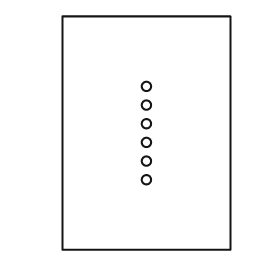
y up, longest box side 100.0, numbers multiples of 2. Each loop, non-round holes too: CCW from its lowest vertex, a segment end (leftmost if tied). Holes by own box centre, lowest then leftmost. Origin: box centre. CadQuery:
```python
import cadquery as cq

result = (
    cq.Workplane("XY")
    .moveTo(-36.0, -50.0)
    .lineTo(36.0, -50.0)
    .lineTo(36.0, 50.0)
    .lineTo(-36.0, 50.0)
    .close()
    .moveTo(0.0, -20.0)
    .circle(2.0)
    .moveTo(0.0, -12.0)
    .circle(2.0)
    .moveTo(0.0, -4.0)
    .circle(2.0)
    .moveTo(0.0, 4.0)
    .circle(2.0)
    .moveTo(0.0, 12.0)
    .circle(2.0)
    .moveTo(0.0, 20.0)
    .circle(2.0)
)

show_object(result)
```